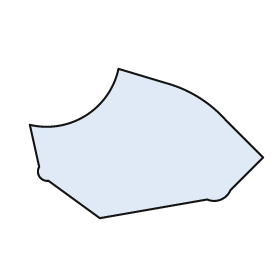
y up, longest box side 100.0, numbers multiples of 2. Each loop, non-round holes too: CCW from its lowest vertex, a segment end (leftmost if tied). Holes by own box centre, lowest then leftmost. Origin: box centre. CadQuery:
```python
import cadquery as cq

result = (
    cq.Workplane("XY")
    .moveTo(-20.0, -32.0)
    .lineTo(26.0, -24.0)
    .threePointArc((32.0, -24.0), (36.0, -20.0))
    .lineTo(50.0, -6.0)
    .lineTo(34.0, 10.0)
    .threePointArc((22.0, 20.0), (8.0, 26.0))
    .lineTo(-12.0, 32.0)
    .threePointArc((-26.0, 12.0), (-50.0, 8.0))
    .lineTo(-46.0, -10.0)
    .threePointArc((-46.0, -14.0), (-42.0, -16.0))
    .close()
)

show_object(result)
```